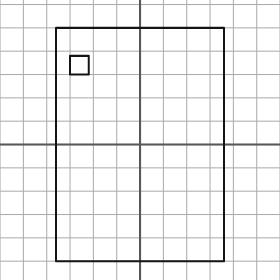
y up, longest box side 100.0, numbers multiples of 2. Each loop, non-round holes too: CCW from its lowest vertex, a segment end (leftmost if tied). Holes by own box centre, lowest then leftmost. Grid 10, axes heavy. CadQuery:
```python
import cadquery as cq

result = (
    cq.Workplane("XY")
    .moveTo(-36.0, -50.0)
    .lineTo(36.0, -50.0)
    .lineTo(36.0, 50.0)
    .lineTo(-36.0, 50.0)
    .close()
    .moveTo(-30.0, 30.0)
    .lineTo(-22.0, 30.0)
    .lineTo(-22.0, 38.0)
    .lineTo(-30.0, 38.0)
    .close()
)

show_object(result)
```